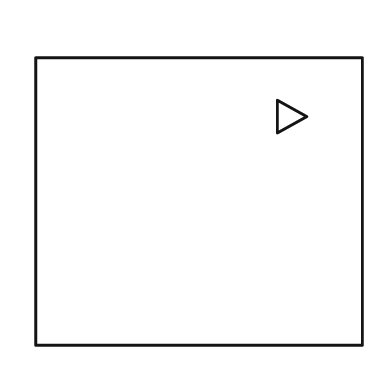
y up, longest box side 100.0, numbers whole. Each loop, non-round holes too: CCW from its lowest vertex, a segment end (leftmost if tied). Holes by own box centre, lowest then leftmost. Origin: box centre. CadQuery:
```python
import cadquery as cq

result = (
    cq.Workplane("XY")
    .moveTo(-50.0, -44.0)
    .lineTo(50.0, -44.0)
    .lineTo(50.0, 44.0)
    .lineTo(-50.0, 44.0)
    .close()
    .moveTo(24.0, 21.0)
    .lineTo(33.0, 26.0)
    .lineTo(24.0, 31.0)
    .close()
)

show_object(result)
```